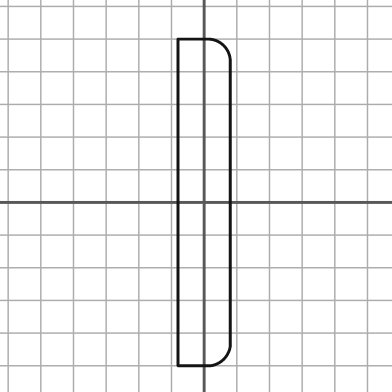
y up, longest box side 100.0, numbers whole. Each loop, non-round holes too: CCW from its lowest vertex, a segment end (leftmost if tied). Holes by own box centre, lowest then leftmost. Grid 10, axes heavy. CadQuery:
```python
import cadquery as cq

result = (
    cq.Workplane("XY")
    .moveTo(-8.0, -50.0)
    .lineTo(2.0, -50.0)
    .threePointArc((6.0, -48.0), (8.0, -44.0))
    .lineTo(8.0, 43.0)
    .threePointArc((6.0, 48.0), (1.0, 50.0))
    .lineTo(-8.0, 50.0)
    .close()
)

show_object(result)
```